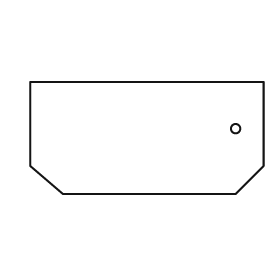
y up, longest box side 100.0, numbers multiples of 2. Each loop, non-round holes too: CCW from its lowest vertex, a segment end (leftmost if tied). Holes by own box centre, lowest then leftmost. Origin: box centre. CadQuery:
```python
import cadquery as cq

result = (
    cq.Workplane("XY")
    .moveTo(-36.0, -24.0)
    .lineTo(38.0, -24.0)
    .lineTo(50.0, -12.0)
    .lineTo(50.0, 24.0)
    .lineTo(-50.0, 24.0)
    .lineTo(-50.0, -12.0)
    .close()
    .moveTo(38.0, 4.0)
    .circle(2.0)
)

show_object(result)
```